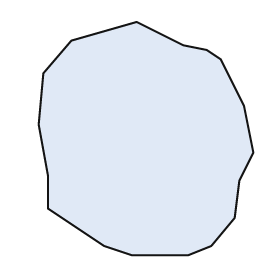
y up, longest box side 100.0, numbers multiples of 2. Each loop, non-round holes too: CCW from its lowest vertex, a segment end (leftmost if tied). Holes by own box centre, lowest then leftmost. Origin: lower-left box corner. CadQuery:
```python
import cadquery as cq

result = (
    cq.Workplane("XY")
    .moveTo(40.0, 0.0)
    .lineTo(64.0, 0.0)
    .lineTo(74.0, 4.0)
    .lineTo(84.0, 16.0)
    .lineTo(86.0, 32.0)
    .lineTo(92.0, 44.0)
    .lineTo(88.0, 64.0)
    .lineTo(78.0, 84.0)
    .lineTo(72.0, 88.0)
    .lineTo(62.0, 90.0)
    .lineTo(42.0, 100.0)
    .lineTo(14.0, 92.0)
    .lineTo(2.0, 78.0)
    .lineTo(0.0, 56.0)
    .lineTo(4.0, 34.0)
    .lineTo(4.0, 20.0)
    .lineTo(28.0, 4.0)
    .close()
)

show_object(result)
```